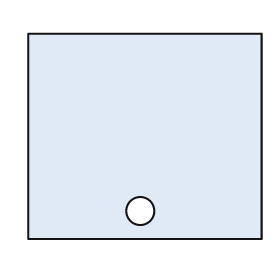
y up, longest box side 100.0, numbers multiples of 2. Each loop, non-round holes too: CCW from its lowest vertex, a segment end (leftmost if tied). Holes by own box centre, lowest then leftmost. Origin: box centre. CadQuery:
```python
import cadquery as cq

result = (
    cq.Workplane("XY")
    .moveTo(-50.0, -44.0)
    .lineTo(50.0, -44.0)
    .lineTo(50.0, 44.0)
    .lineTo(-50.0, 44.0)
    .close()
    .moveTo(-2.0, -32.0)
    .circle(6.0)
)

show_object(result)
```